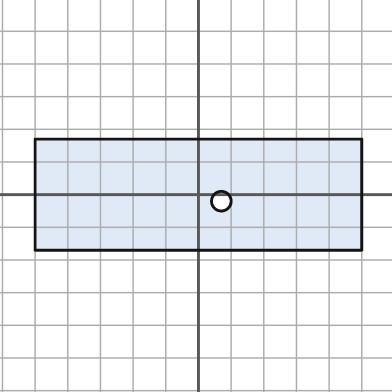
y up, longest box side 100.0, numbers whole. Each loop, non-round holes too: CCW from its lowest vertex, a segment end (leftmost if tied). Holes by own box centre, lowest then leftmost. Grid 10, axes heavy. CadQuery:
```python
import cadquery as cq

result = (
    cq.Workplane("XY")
    .moveTo(-50.0, -17.0)
    .lineTo(50.0, -17.0)
    .lineTo(50.0, 17.0)
    .lineTo(-50.0, 17.0)
    .close()
    .moveTo(7.0, -2.0)
    .circle(3.0)
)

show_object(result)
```